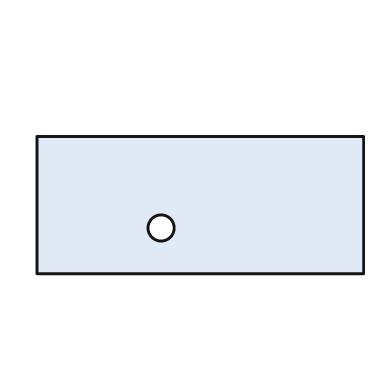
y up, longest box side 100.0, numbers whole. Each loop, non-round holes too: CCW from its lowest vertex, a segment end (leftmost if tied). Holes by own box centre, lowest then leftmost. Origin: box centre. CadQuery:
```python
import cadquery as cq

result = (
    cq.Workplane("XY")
    .moveTo(-50.0, -21.0)
    .lineTo(50.0, -21.0)
    .lineTo(50.0, 21.0)
    .lineTo(-50.0, 21.0)
    .close()
    .moveTo(-12.0, -7.0)
    .circle(4.0)
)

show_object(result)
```